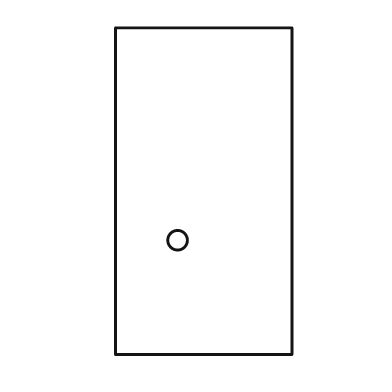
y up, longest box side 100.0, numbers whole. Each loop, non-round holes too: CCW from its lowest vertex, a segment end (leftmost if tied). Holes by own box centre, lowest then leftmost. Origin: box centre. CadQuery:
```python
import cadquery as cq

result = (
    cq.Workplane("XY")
    .moveTo(-27.0, -50.0)
    .lineTo(27.0, -50.0)
    .lineTo(27.0, 50.0)
    .lineTo(-27.0, 50.0)
    .close()
    .moveTo(-8.0, -15.0)
    .circle(3.0)
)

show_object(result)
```